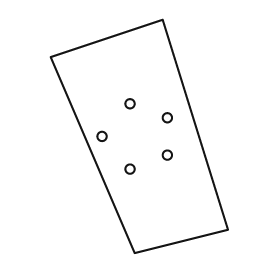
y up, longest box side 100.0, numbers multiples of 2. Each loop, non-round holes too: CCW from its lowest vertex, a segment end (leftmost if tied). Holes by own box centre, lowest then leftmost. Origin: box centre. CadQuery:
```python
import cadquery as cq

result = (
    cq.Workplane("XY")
    .moveTo(-2.0, -50.0)
    .lineTo(38.0, -40.0)
    .lineTo(10.0, 50.0)
    .lineTo(-38.0, 34.0)
    .close()
    .moveTo(-4.0, -14.0)
    .circle(2.0)
    .moveTo(12.0, -8.0)
    .circle(2.0)
    .moveTo(-16.0, 0.0)
    .circle(2.0)
    .moveTo(12.0, 8.0)
    .circle(2.0)
    .moveTo(-4.0, 14.0)
    .circle(2.0)
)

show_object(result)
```